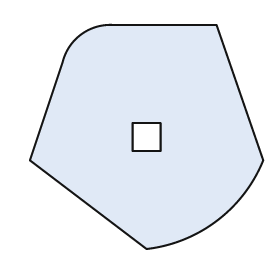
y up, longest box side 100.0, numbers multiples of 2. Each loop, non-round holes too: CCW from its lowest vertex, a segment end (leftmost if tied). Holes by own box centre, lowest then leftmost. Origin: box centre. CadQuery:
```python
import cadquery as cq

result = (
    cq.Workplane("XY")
    .moveTo(0.0, -48.0)
    .threePointArc((30.0, -36.0), (50.0, -10.0))
    .lineTo(30.0, 48.0)
    .lineTo(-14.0, 48.0)
    .threePointArc((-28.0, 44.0), (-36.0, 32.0))
    .lineTo(-50.0, -10.0)
    .close()
    .moveTo(-6.0, -6.0)
    .lineTo(6.0, -6.0)
    .lineTo(6.0, 6.0)
    .lineTo(-6.0, 6.0)
    .close()
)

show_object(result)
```